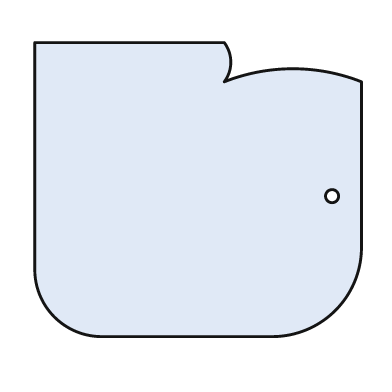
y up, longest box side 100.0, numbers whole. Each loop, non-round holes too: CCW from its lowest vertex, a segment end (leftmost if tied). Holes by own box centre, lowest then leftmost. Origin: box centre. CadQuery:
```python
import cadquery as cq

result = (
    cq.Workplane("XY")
    .moveTo(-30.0, -45.0)
    .lineTo(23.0, -45.0)
    .threePointArc((42.0, -37.0), (50.0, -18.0))
    .lineTo(50.0, 33.0)
    .threePointArc((29.0, 37.0), (8.0, 33.0))
    .threePointArc((10.0, 39.0), (8.0, 45.0))
    .lineTo(-50.0, 45.0)
    .lineTo(-50.0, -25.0)
    .threePointArc((-44.0, -39.0), (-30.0, -45.0))
    .close()
    .moveTo(41.0, -2.0)
    .circle(2.0)
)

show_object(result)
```